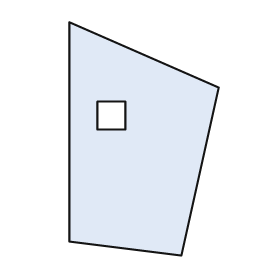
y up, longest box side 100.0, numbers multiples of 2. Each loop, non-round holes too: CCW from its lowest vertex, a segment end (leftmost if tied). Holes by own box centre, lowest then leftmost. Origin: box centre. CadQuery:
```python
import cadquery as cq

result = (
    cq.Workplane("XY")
    .moveTo(16.0, -50.0)
    .lineTo(32.0, 22.0)
    .lineTo(-32.0, 50.0)
    .lineTo(-32.0, -44.0)
    .close()
    .moveTo(-20.0, 4.0)
    .lineTo(-8.0, 4.0)
    .lineTo(-8.0, 16.0)
    .lineTo(-20.0, 16.0)
    .close()
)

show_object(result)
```